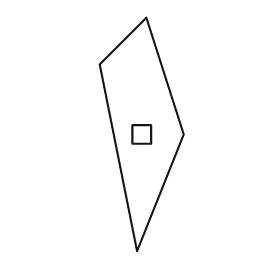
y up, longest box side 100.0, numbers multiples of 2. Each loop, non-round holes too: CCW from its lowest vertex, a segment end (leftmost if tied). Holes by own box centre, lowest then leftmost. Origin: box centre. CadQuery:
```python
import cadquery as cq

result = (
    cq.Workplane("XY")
    .moveTo(-2.0, -50.0)
    .lineTo(18.0, 0.0)
    .lineTo(2.0, 50.0)
    .lineTo(-18.0, 30.0)
    .close()
    .moveTo(-4.0, -4.0)
    .lineTo(4.0, -4.0)
    .lineTo(4.0, 4.0)
    .lineTo(-4.0, 4.0)
    .close()
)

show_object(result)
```